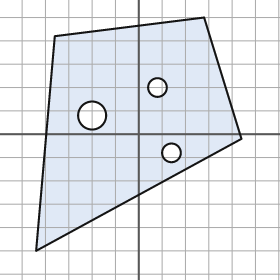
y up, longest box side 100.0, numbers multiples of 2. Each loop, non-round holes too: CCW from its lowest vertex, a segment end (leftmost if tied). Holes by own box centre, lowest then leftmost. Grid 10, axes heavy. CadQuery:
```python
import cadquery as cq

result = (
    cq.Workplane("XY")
    .moveTo(-44.0, -50.0)
    .lineTo(44.0, -2.0)
    .lineTo(28.0, 50.0)
    .lineTo(-36.0, 42.0)
    .close()
    .moveTo(14.0, -8.0)
    .circle(4.0)
    .moveTo(-20.0, 8.0)
    .circle(6.0)
    .moveTo(8.0, 20.0)
    .circle(4.0)
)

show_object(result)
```